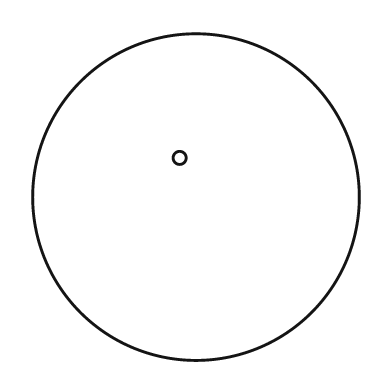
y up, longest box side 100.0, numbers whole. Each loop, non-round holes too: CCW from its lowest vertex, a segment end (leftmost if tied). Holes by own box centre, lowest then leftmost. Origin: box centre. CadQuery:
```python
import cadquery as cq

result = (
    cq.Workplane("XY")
    .moveTo(0.0, 0.0)
    .circle(50.0)
    .moveTo(-5.0, 12.0)
    .circle(2.0)
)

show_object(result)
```